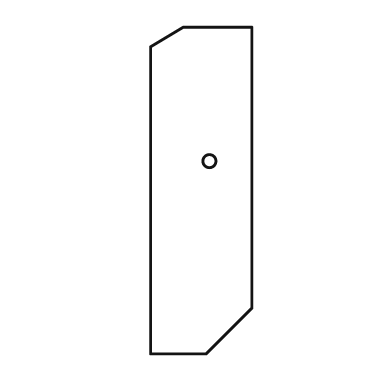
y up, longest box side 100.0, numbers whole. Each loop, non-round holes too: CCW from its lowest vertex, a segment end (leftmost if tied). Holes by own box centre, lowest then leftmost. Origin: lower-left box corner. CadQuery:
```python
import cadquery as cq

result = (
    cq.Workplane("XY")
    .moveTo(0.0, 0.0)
    .lineTo(17.0, 0.0)
    .lineTo(31.0, 14.0)
    .lineTo(31.0, 100.0)
    .lineTo(10.0, 100.0)
    .lineTo(0.0, 94.0)
    .close()
    .moveTo(18.0, 59.0)
    .circle(2.0)
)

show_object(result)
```